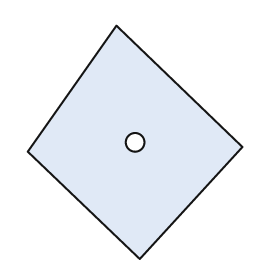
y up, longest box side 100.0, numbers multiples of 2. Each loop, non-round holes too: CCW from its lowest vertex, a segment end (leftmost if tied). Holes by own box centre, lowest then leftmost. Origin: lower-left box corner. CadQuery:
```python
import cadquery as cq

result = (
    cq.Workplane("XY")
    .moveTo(48.0, 0.0)
    .lineTo(92.0, 48.0)
    .lineTo(38.0, 100.0)
    .lineTo(0.0, 46.0)
    .close()
    .moveTo(46.0, 50.0)
    .circle(4.0)
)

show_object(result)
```